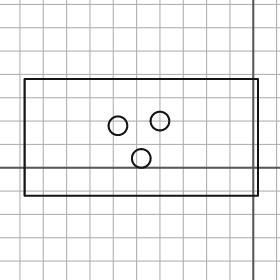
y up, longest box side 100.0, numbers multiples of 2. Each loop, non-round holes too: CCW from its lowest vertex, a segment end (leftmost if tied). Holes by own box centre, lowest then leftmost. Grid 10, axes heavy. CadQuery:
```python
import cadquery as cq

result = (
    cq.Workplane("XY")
    .moveTo(-98.0, -12.0)
    .lineTo(2.0, -12.0)
    .lineTo(2.0, 38.0)
    .lineTo(-98.0, 38.0)
    .close()
    .moveTo(-48.0, 4.0)
    .circle(4.0)
    .moveTo(-58.0, 18.0)
    .circle(4.0)
    .moveTo(-40.0, 20.0)
    .circle(4.0)
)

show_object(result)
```